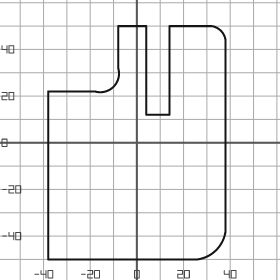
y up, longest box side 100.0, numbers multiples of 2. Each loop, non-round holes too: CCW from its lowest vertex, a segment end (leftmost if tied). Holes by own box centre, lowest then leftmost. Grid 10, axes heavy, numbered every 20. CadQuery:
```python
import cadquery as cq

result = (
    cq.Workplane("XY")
    .moveTo(-38.0, -50.0)
    .lineTo(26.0, -50.0)
    .threePointArc((34.0, -46.0), (38.0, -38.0))
    .lineTo(38.0, 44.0)
    .threePointArc((36.0, 48.0), (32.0, 50.0))
    .lineTo(14.0, 50.0)
    .lineTo(14.0, 12.0)
    .lineTo(4.0, 12.0)
    .lineTo(4.0, 50.0)
    .lineTo(-8.0, 50.0)
    .lineTo(-8.0, 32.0)
    .threePointArc((-10.0, 24.0), (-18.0, 22.0))
    .lineTo(-38.0, 22.0)
    .close()
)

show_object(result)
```